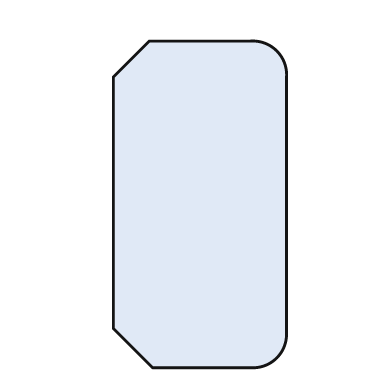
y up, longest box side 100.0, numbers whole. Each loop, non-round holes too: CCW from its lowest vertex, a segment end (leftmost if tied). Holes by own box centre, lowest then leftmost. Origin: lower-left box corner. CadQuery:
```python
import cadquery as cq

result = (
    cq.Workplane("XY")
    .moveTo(12.0, 0.0)
    .lineTo(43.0, 0.0)
    .threePointArc((50.0, 3.0), (53.0, 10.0))
    .lineTo(53.0, 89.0)
    .threePointArc((50.0, 97.0), (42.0, 100.0))
    .lineTo(11.0, 100.0)
    .lineTo(0.0, 89.0)
    .lineTo(0.0, 12.0)
    .close()
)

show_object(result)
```